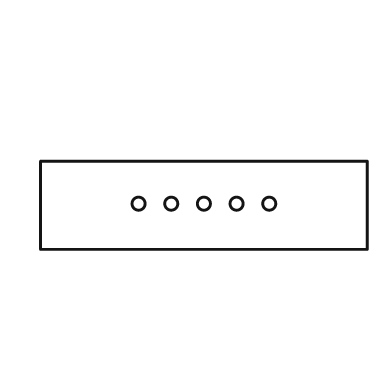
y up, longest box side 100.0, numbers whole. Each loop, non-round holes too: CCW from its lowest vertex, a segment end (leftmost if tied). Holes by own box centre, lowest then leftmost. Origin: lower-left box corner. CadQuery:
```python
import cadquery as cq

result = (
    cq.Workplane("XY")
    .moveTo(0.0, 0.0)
    .lineTo(100.0, 0.0)
    .lineTo(100.0, 27.0)
    .lineTo(0.0, 27.0)
    .close()
    .moveTo(30.0, 14.0)
    .circle(2.0)
    .moveTo(40.0, 14.0)
    .circle(2.0)
    .moveTo(50.0, 14.0)
    .circle(2.0)
    .moveTo(60.0, 14.0)
    .circle(2.0)
    .moveTo(70.0, 14.0)
    .circle(2.0)
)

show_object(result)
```